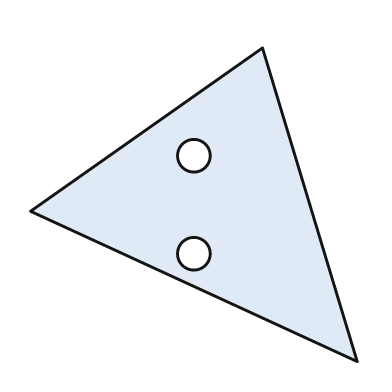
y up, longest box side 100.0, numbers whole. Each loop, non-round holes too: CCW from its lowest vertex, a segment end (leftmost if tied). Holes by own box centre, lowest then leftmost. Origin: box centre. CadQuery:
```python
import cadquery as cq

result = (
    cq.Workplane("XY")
    .moveTo(50.0, -48.0)
    .lineTo(21.0, 48.0)
    .lineTo(-50.0, -2.0)
    .close()
    .moveTo(0.0, -15.0)
    .circle(5.0)
    .moveTo(0.0, 15.0)
    .circle(5.0)
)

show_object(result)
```